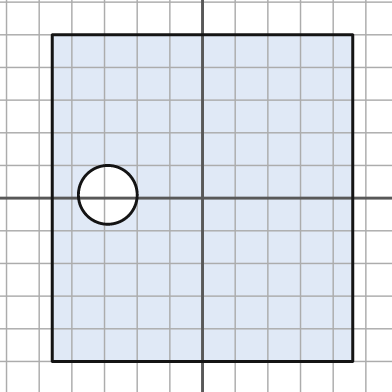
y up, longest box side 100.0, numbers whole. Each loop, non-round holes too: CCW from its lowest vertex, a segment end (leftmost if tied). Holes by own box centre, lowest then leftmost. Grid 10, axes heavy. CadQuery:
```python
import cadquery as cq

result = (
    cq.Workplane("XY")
    .moveTo(-46.0, -50.0)
    .lineTo(46.0, -50.0)
    .lineTo(46.0, 50.0)
    .lineTo(-46.0, 50.0)
    .close()
    .moveTo(-29.0, 1.0)
    .circle(9.0)
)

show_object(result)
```